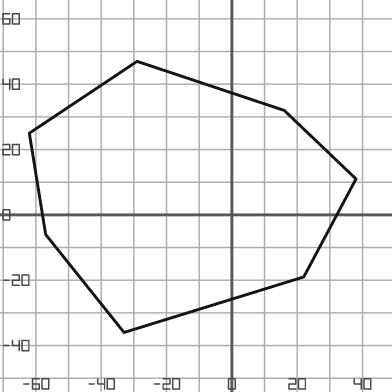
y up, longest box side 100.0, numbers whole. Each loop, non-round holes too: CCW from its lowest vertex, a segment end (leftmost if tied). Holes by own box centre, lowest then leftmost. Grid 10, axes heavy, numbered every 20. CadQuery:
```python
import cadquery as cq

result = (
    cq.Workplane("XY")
    .moveTo(-33.0, -36.0)
    .lineTo(22.0, -19.0)
    .lineTo(38.0, 11.0)
    .lineTo(16.0, 32.0)
    .lineTo(-29.0, 47.0)
    .lineTo(-62.0, 25.0)
    .lineTo(-57.0, -6.0)
    .close()
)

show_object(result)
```